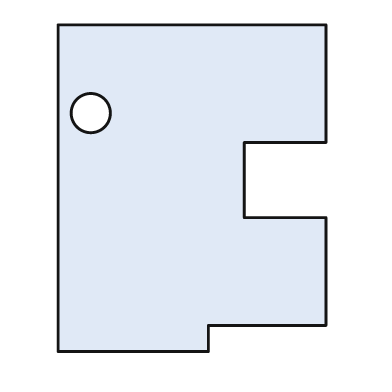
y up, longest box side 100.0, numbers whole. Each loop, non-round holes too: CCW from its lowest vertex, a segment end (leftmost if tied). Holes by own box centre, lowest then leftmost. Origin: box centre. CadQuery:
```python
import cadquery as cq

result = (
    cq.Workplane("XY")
    .moveTo(-41.0, -50.0)
    .lineTo(5.0, -50.0)
    .lineTo(5.0, -42.0)
    .lineTo(41.0, -42.0)
    .lineTo(41.0, -9.0)
    .lineTo(16.0, -9.0)
    .lineTo(16.0, 14.0)
    .lineTo(41.0, 14.0)
    .lineTo(41.0, 50.0)
    .lineTo(-41.0, 50.0)
    .close()
    .moveTo(-31.0, 23.0)
    .circle(6.0)
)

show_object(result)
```